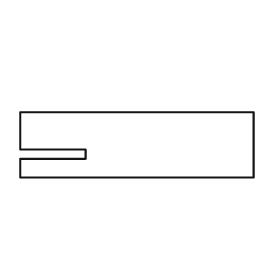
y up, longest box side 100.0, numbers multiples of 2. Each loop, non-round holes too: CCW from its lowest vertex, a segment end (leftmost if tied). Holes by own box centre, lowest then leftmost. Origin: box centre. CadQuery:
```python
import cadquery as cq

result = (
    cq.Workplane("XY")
    .moveTo(-50.0, -14.0)
    .lineTo(50.0, -14.0)
    .lineTo(50.0, 14.0)
    .lineTo(-50.0, 14.0)
    .lineTo(-50.0, -2.0)
    .lineTo(-22.0, -2.0)
    .lineTo(-22.0, -6.0)
    .lineTo(-50.0, -6.0)
    .close()
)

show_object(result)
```